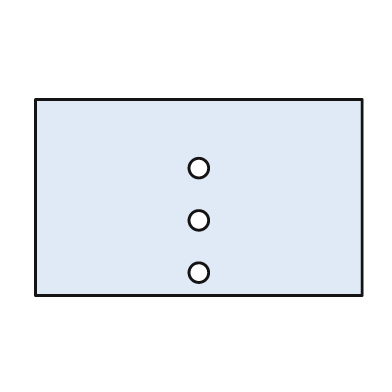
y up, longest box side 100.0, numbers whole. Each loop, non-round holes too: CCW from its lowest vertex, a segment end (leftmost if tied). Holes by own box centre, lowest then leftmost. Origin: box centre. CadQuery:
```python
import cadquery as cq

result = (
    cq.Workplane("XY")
    .moveTo(-50.0, -30.0)
    .lineTo(50.0, -30.0)
    .lineTo(50.0, 30.0)
    .lineTo(-50.0, 30.0)
    .close()
    .moveTo(0.0, -23.0)
    .circle(3.0)
    .moveTo(0.0, -7.0)
    .circle(3.0)
    .moveTo(0.0, 9.0)
    .circle(3.0)
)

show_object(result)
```